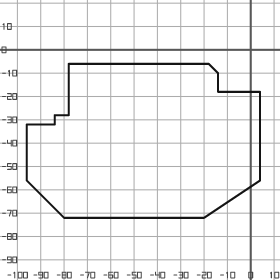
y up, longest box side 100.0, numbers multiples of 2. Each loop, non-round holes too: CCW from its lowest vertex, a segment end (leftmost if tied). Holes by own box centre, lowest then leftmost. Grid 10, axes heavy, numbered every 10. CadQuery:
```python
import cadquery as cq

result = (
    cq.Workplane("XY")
    .moveTo(-80.0, -72.0)
    .lineTo(-20.0, -72.0)
    .lineTo(4.0, -56.0)
    .lineTo(4.0, -18.0)
    .lineTo(-14.0, -18.0)
    .lineTo(-14.0, -10.0)
    .lineTo(-18.0, -6.0)
    .lineTo(-78.0, -6.0)
    .lineTo(-78.0, -28.0)
    .lineTo(-84.0, -28.0)
    .lineTo(-84.0, -32.0)
    .lineTo(-96.0, -32.0)
    .lineTo(-96.0, -56.0)
    .close()
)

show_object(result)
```